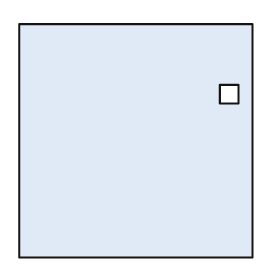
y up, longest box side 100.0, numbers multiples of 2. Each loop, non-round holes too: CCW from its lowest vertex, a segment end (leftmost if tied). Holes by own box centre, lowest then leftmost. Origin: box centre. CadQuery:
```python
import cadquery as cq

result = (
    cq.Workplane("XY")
    .moveTo(-50.0, -50.0)
    .lineTo(50.0, -50.0)
    .lineTo(50.0, 50.0)
    .lineTo(-50.0, 50.0)
    .close()
    .moveTo(36.0, 16.0)
    .lineTo(44.0, 16.0)
    .lineTo(44.0, 24.0)
    .lineTo(36.0, 24.0)
    .close()
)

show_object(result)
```